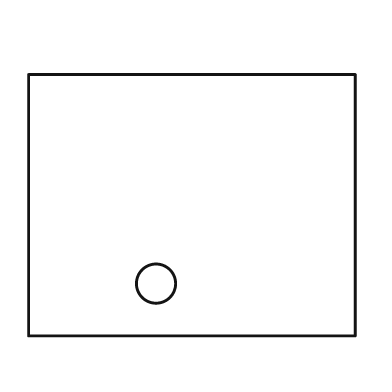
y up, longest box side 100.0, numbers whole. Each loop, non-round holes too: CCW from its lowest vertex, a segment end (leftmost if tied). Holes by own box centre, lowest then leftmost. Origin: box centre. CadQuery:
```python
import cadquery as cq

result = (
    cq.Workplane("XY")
    .moveTo(-50.0, -40.0)
    .lineTo(50.0, -40.0)
    .lineTo(50.0, 40.0)
    .lineTo(-50.0, 40.0)
    .close()
    .moveTo(-11.0, -24.0)
    .circle(6.0)
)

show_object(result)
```